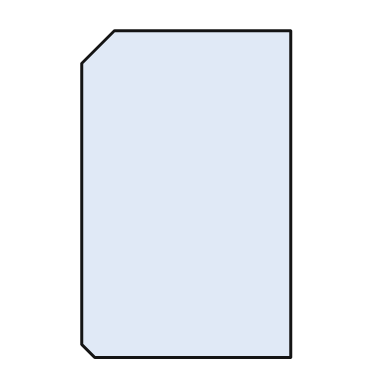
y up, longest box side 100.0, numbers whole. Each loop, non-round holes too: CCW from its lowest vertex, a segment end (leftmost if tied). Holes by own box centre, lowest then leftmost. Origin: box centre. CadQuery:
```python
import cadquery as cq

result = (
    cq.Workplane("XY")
    .moveTo(-28.0, -50.0)
    .lineTo(32.0, -50.0)
    .lineTo(32.0, 50.0)
    .lineTo(-22.0, 50.0)
    .lineTo(-32.0, 40.0)
    .lineTo(-32.0, -46.0)
    .close()
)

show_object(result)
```